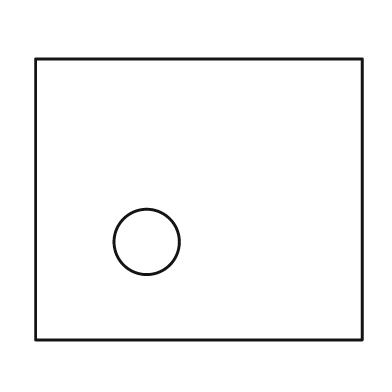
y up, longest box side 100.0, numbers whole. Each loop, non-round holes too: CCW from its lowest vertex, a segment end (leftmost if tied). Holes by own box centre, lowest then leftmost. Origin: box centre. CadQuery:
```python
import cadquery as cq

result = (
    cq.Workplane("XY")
    .moveTo(-50.0, -43.0)
    .lineTo(50.0, -43.0)
    .lineTo(50.0, 43.0)
    .lineTo(-50.0, 43.0)
    .close()
    .moveTo(-16.0, -13.0)
    .circle(10.0)
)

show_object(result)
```